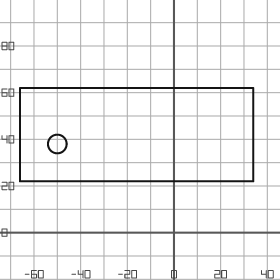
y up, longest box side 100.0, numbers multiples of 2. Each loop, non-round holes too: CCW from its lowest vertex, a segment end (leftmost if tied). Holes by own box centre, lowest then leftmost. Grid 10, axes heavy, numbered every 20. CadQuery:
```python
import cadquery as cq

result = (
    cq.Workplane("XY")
    .moveTo(-66.0, 22.0)
    .lineTo(34.0, 22.0)
    .lineTo(34.0, 62.0)
    .lineTo(-66.0, 62.0)
    .close()
    .moveTo(-50.0, 38.0)
    .circle(4.0)
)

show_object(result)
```